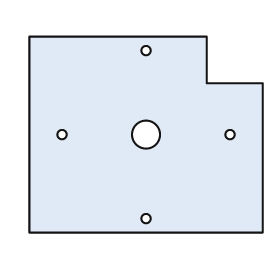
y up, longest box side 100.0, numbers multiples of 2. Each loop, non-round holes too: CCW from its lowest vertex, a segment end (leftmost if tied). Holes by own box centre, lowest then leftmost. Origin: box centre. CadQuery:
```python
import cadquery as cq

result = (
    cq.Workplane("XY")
    .moveTo(-50.0, -42.0)
    .lineTo(50.0, -42.0)
    .lineTo(50.0, 22.0)
    .lineTo(26.0, 22.0)
    .lineTo(26.0, 42.0)
    .lineTo(-50.0, 42.0)
    .close()
    .moveTo(0.0, -36.0)
    .circle(2.0)
    .moveTo(-36.0, 0.0)
    .circle(2.0)
    .moveTo(0.0, 0.0)
    .circle(6.0)
    .moveTo(36.0, 0.0)
    .circle(2.0)
    .moveTo(0.0, 36.0)
    .circle(2.0)
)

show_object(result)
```